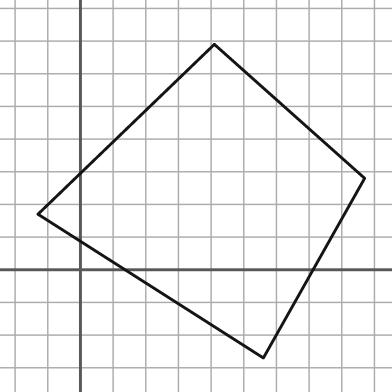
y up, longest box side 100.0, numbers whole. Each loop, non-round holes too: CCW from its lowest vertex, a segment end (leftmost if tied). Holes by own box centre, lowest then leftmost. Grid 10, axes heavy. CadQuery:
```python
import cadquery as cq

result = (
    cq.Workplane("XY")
    .moveTo(56.0, -27.0)
    .lineTo(87.0, 28.0)
    .lineTo(41.0, 69.0)
    .lineTo(-13.0, 17.0)
    .close()
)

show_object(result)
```